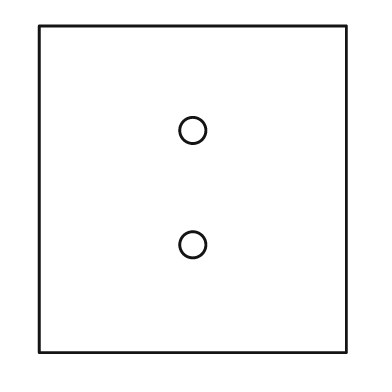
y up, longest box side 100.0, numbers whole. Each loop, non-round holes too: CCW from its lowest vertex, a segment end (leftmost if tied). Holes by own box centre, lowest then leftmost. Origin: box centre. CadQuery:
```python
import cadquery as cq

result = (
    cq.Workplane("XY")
    .moveTo(-47.0, -50.0)
    .lineTo(47.0, -50.0)
    .lineTo(47.0, 50.0)
    .lineTo(-47.0, 50.0)
    .close()
    .moveTo(0.0, -17.0)
    .circle(4.0)
    .moveTo(0.0, 18.0)
    .circle(4.0)
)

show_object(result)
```